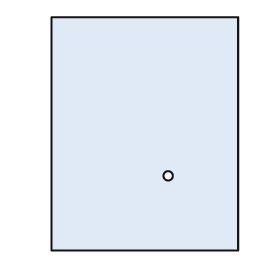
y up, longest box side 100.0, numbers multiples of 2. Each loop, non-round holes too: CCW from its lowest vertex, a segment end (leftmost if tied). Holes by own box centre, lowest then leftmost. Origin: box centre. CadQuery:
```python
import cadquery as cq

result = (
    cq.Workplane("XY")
    .moveTo(-40.0, -50.0)
    .lineTo(40.0, -50.0)
    .lineTo(40.0, 50.0)
    .lineTo(-40.0, 50.0)
    .close()
    .moveTo(10.0, -18.0)
    .circle(2.0)
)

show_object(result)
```